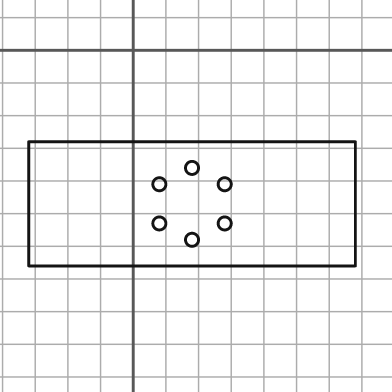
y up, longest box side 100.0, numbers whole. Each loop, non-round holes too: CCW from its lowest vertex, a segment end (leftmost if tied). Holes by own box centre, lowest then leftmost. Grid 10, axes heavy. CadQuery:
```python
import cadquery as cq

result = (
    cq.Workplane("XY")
    .moveTo(-32.0, -66.0)
    .lineTo(68.0, -66.0)
    .lineTo(68.0, -28.0)
    .lineTo(-32.0, -28.0)
    .close()
    .moveTo(18.0, -58.0)
    .circle(2.0)
    .moveTo(8.0, -53.0)
    .circle(2.0)
    .moveTo(28.0, -53.0)
    .circle(2.0)
    .moveTo(8.0, -41.0)
    .circle(2.0)
    .moveTo(28.0, -41.0)
    .circle(2.0)
    .moveTo(18.0, -36.0)
    .circle(2.0)
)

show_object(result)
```